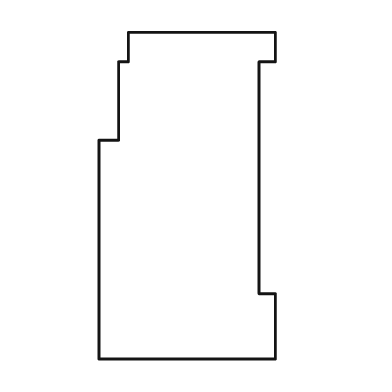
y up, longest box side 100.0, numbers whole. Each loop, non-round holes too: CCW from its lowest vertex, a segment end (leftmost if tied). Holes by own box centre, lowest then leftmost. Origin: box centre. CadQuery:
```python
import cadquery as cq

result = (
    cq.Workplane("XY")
    .moveTo(-27.0, -50.0)
    .lineTo(27.0, -50.0)
    .lineTo(27.0, -30.0)
    .lineTo(22.0, -30.0)
    .lineTo(22.0, 41.0)
    .lineTo(27.0, 41.0)
    .lineTo(27.0, 50.0)
    .lineTo(-18.0, 50.0)
    .lineTo(-18.0, 41.0)
    .lineTo(-21.0, 41.0)
    .lineTo(-21.0, 17.0)
    .lineTo(-27.0, 17.0)
    .close()
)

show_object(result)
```